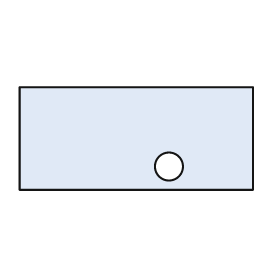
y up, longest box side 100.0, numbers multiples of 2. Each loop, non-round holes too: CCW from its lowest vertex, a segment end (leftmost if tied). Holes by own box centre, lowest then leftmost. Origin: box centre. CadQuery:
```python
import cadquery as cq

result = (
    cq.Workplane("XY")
    .moveTo(-50.0, -22.0)
    .lineTo(50.0, -22.0)
    .lineTo(50.0, 22.0)
    .lineTo(-50.0, 22.0)
    .close()
    .moveTo(14.0, -12.0)
    .circle(6.0)
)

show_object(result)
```